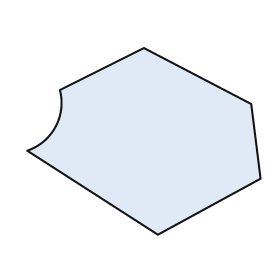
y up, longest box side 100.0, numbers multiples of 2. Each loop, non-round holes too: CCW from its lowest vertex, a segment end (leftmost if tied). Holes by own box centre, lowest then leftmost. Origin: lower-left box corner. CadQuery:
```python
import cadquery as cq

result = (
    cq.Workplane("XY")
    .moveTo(56.0, 0.0)
    .lineTo(100.0, 24.0)
    .lineTo(96.0, 56.0)
    .lineTo(50.0, 80.0)
    .lineTo(14.0, 62.0)
    .threePointArc((12.0, 46.0), (0.0, 36.0))
    .close()
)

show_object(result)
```